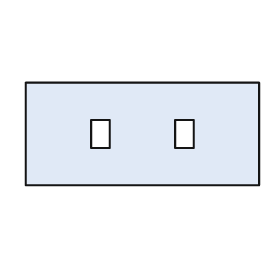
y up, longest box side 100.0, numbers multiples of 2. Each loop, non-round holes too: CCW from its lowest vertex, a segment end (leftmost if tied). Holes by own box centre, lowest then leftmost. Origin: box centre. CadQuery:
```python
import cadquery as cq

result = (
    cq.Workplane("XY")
    .moveTo(-50.0, -22.0)
    .lineTo(50.0, -22.0)
    .lineTo(50.0, 22.0)
    .lineTo(-50.0, 22.0)
    .close()
    .moveTo(-22.0, -6.0)
    .lineTo(-14.0, -6.0)
    .lineTo(-14.0, 6.0)
    .lineTo(-22.0, 6.0)
    .close()
    .moveTo(14.0, -6.0)
    .lineTo(22.0, -6.0)
    .lineTo(22.0, 6.0)
    .lineTo(14.0, 6.0)
    .close()
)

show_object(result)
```